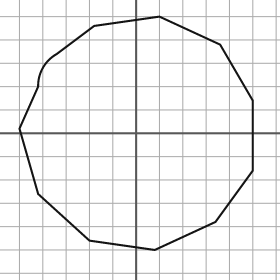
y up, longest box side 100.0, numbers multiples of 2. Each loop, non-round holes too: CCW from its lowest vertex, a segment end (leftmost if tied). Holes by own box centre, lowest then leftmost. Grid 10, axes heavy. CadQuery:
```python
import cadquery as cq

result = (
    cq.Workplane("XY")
    .moveTo(8.0, -50.0)
    .lineTo(34.0, -38.0)
    .lineTo(50.0, -16.0)
    .lineTo(50.0, 14.0)
    .lineTo(36.0, 38.0)
    .lineTo(10.0, 50.0)
    .lineTo(-18.0, 46.0)
    .lineTo(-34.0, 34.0)
    .threePointArc((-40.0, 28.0), (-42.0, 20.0))
    .lineTo(-50.0, 2.0)
    .lineTo(-42.0, -26.0)
    .lineTo(-20.0, -46.0)
    .close()
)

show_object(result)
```